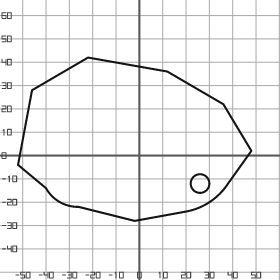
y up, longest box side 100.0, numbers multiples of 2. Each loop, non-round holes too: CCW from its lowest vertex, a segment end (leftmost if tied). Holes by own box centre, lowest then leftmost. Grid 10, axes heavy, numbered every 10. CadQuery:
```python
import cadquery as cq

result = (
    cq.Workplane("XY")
    .moveTo(-2.0, -28.0)
    .lineTo(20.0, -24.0)
    .threePointArc((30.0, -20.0), (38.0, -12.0))
    .lineTo(48.0, 2.0)
    .lineTo(36.0, 22.0)
    .lineTo(12.0, 36.0)
    .lineTo(-22.0, 42.0)
    .lineTo(-46.0, 28.0)
    .lineTo(-52.0, -4.0)
    .lineTo(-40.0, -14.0)
    .threePointArc((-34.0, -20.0), (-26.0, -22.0))
    .close()
    .moveTo(26.0, -12.0)
    .circle(4.0)
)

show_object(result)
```